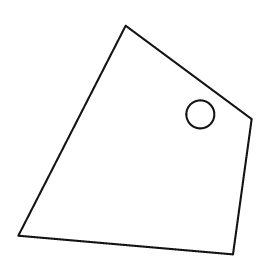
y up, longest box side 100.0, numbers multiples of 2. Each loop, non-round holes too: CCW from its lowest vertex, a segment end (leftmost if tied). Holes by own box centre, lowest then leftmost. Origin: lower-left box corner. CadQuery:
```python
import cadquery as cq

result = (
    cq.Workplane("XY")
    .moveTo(92.0, 0.0)
    .lineTo(100.0, 58.0)
    .lineTo(46.0, 98.0)
    .lineTo(0.0, 8.0)
    .close()
    .moveTo(78.0, 60.0)
    .circle(6.0)
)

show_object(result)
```